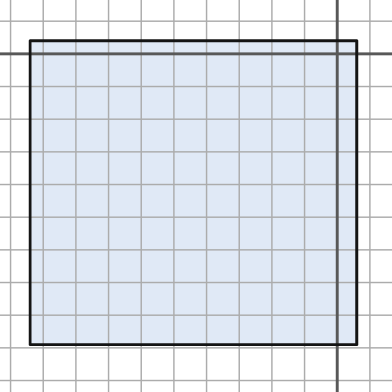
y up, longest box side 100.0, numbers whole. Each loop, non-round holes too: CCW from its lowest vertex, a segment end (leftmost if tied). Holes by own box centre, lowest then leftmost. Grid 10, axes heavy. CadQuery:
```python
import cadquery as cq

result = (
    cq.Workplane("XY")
    .moveTo(-94.0, -89.0)
    .lineTo(6.0, -89.0)
    .lineTo(6.0, 4.0)
    .lineTo(-94.0, 4.0)
    .close()
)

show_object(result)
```